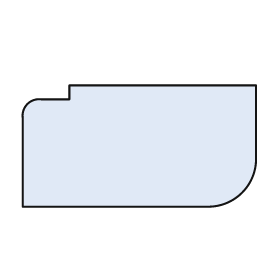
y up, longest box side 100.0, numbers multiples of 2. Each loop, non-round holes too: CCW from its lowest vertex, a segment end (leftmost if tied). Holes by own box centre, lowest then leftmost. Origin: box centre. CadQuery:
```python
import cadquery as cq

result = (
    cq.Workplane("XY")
    .moveTo(-50.0, -26.0)
    .lineTo(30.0, -26.0)
    .threePointArc((44.0, -20.0), (50.0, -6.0))
    .lineTo(50.0, 26.0)
    .lineTo(-30.0, 26.0)
    .lineTo(-30.0, 20.0)
    .lineTo(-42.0, 20.0)
    .threePointArc((-48.0, 18.0), (-50.0, 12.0))
    .close()
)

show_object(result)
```